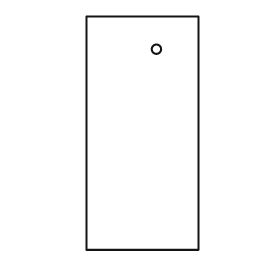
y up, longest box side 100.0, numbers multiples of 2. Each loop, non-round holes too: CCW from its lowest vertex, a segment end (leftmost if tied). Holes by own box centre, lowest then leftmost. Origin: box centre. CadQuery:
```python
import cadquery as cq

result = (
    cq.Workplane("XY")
    .moveTo(-24.0, -50.0)
    .lineTo(24.0, -50.0)
    .lineTo(24.0, 50.0)
    .lineTo(-24.0, 50.0)
    .close()
    .moveTo(6.0, 36.0)
    .circle(2.0)
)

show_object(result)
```